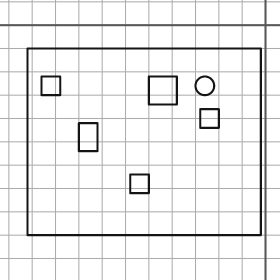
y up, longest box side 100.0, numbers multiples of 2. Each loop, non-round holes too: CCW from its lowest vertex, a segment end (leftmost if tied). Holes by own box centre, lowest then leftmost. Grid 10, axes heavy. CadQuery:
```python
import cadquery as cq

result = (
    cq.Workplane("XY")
    .moveTo(-102.0, -90.0)
    .lineTo(-2.0, -90.0)
    .lineTo(-2.0, -10.0)
    .lineTo(-102.0, -10.0)
    .close()
    .moveTo(-58.0, -72.0)
    .lineTo(-50.0, -72.0)
    .lineTo(-50.0, -64.0)
    .lineTo(-58.0, -64.0)
    .close()
    .moveTo(-80.0, -54.0)
    .lineTo(-72.0, -54.0)
    .lineTo(-72.0, -42.0)
    .lineTo(-80.0, -42.0)
    .close()
    .moveTo(-28.0, -44.0)
    .lineTo(-20.0, -44.0)
    .lineTo(-20.0, -36.0)
    .lineTo(-28.0, -36.0)
    .close()
    .moveTo(-50.0, -34.0)
    .lineTo(-38.0, -34.0)
    .lineTo(-38.0, -22.0)
    .lineTo(-50.0, -22.0)
    .close()
    .moveTo(-96.0, -30.0)
    .lineTo(-88.0, -30.0)
    .lineTo(-88.0, -22.0)
    .lineTo(-96.0, -22.0)
    .close()
    .moveTo(-26.0, -26.0)
    .circle(4.0)
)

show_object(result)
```